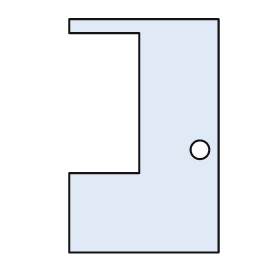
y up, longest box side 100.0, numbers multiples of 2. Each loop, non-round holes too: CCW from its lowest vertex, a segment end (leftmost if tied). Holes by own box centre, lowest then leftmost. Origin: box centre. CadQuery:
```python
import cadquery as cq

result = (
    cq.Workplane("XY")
    .moveTo(-32.0, -50.0)
    .lineTo(32.0, -50.0)
    .lineTo(32.0, 50.0)
    .lineTo(-32.0, 50.0)
    .lineTo(-32.0, 44.0)
    .lineTo(-2.0, 44.0)
    .lineTo(-2.0, -16.0)
    .lineTo(-32.0, -16.0)
    .close()
    .moveTo(24.0, -6.0)
    .circle(4.0)
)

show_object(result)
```